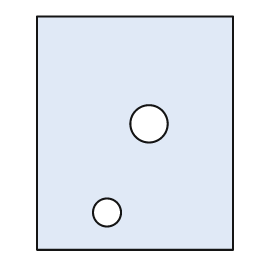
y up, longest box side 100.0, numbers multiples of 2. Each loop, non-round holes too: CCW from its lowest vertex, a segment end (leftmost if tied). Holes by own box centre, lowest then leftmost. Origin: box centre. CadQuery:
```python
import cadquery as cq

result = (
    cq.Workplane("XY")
    .moveTo(-42.0, -50.0)
    .lineTo(42.0, -50.0)
    .lineTo(42.0, 50.0)
    .lineTo(-42.0, 50.0)
    .close()
    .moveTo(-12.0, -34.0)
    .circle(6.0)
    .moveTo(6.0, 4.0)
    .circle(8.0)
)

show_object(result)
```